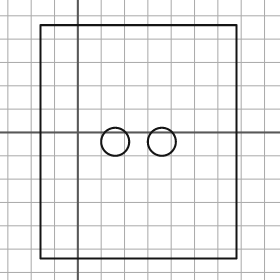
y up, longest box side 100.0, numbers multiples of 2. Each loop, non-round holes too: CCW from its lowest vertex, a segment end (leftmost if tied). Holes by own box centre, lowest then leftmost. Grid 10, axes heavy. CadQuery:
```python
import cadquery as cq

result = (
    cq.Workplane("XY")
    .moveTo(-16.0, -54.0)
    .lineTo(68.0, -54.0)
    .lineTo(68.0, 46.0)
    .lineTo(-16.0, 46.0)
    .close()
    .moveTo(16.0, -4.0)
    .circle(6.0)
    .moveTo(36.0, -4.0)
    .circle(6.0)
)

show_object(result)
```